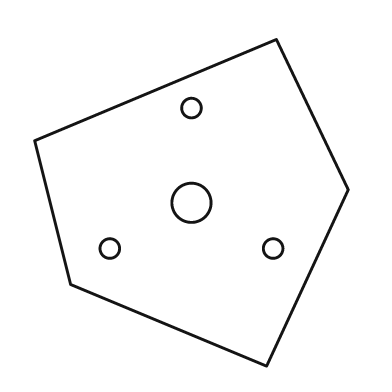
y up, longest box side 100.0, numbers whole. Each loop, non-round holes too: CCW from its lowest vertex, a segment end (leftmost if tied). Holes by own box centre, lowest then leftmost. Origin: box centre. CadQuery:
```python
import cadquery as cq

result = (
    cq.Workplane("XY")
    .moveTo(23.0, -50.0)
    .lineTo(48.0, 4.0)
    .lineTo(26.0, 50.0)
    .lineTo(-48.0, 19.0)
    .lineTo(-37.0, -25.0)
    .close()
    .moveTo(-25.0, -14.0)
    .circle(3.0)
    .moveTo(25.0, -14.0)
    .circle(3.0)
    .moveTo(0.0, 0.0)
    .circle(6.0)
    .moveTo(0.0, 29.0)
    .circle(3.0)
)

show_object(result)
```